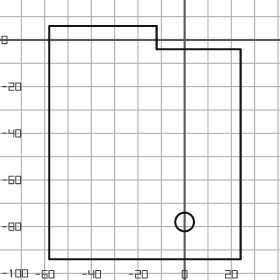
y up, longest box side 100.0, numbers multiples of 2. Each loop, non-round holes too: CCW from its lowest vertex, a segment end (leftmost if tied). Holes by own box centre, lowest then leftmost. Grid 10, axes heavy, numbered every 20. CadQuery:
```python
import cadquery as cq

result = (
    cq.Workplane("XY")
    .moveTo(-58.0, -94.0)
    .lineTo(24.0, -94.0)
    .lineTo(24.0, -4.0)
    .lineTo(-12.0, -4.0)
    .lineTo(-12.0, 6.0)
    .lineTo(-58.0, 6.0)
    .close()
    .moveTo(0.0, -78.0)
    .circle(4.0)
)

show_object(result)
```